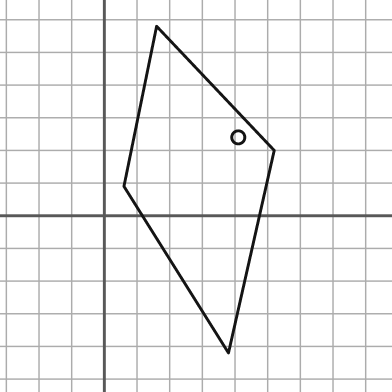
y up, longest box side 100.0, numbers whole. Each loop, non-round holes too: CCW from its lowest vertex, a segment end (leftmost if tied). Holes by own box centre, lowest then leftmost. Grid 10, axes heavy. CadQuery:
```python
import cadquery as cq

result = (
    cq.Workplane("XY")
    .moveTo(38.0, -42.0)
    .lineTo(52.0, 20.0)
    .lineTo(16.0, 58.0)
    .lineTo(6.0, 9.0)
    .close()
    .moveTo(41.0, 24.0)
    .circle(2.0)
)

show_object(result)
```